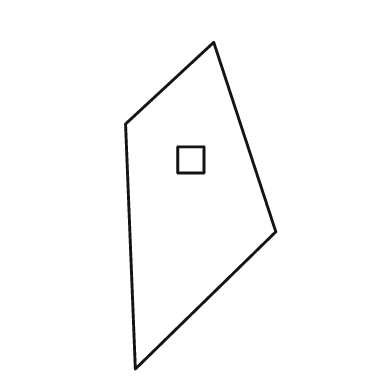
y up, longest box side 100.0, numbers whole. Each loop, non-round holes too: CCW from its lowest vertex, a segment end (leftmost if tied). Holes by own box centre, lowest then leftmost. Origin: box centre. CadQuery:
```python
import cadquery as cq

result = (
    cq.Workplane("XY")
    .moveTo(-20.0, -50.0)
    .lineTo(23.0, -8.0)
    .lineTo(4.0, 50.0)
    .lineTo(-23.0, 25.0)
    .close()
    .moveTo(-7.0, 10.0)
    .lineTo(1.0, 10.0)
    .lineTo(1.0, 18.0)
    .lineTo(-7.0, 18.0)
    .close()
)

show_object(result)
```